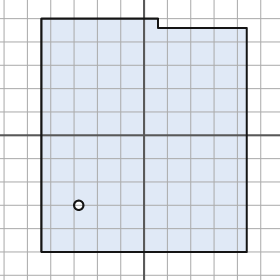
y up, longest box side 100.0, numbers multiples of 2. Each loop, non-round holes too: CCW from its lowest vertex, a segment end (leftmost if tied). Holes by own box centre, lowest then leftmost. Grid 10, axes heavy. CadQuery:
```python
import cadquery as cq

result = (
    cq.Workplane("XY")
    .moveTo(-44.0, -50.0)
    .lineTo(44.0, -50.0)
    .lineTo(44.0, 46.0)
    .lineTo(6.0, 46.0)
    .lineTo(6.0, 50.0)
    .lineTo(-44.0, 50.0)
    .close()
    .moveTo(-28.0, -30.0)
    .circle(2.0)
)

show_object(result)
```